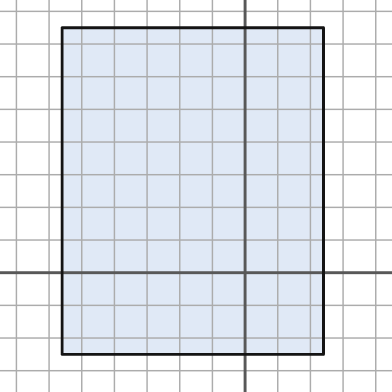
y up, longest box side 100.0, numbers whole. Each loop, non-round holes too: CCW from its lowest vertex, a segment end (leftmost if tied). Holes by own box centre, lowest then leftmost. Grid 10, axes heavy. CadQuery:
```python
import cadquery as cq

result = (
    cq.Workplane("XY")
    .moveTo(-56.0, -25.0)
    .lineTo(24.0, -25.0)
    .lineTo(24.0, 75.0)
    .lineTo(-56.0, 75.0)
    .close()
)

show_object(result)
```